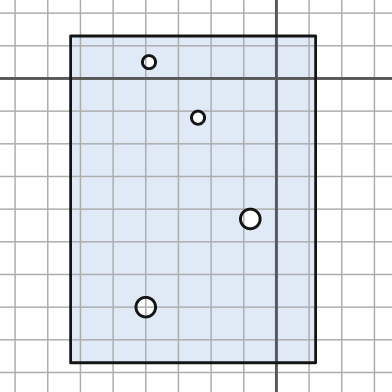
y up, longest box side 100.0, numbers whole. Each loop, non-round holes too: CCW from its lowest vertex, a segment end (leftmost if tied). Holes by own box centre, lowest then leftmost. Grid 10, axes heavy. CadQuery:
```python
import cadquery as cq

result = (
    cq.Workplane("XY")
    .moveTo(-63.0, -87.0)
    .lineTo(12.0, -87.0)
    .lineTo(12.0, 13.0)
    .lineTo(-63.0, 13.0)
    .close()
    .moveTo(-40.0, -70.0)
    .circle(3.0)
    .moveTo(-8.0, -43.0)
    .circle(3.0)
    .moveTo(-24.0, -12.0)
    .circle(2.0)
    .moveTo(-39.0, 5.0)
    .circle(2.0)
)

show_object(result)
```